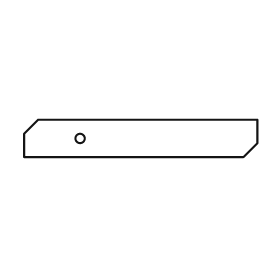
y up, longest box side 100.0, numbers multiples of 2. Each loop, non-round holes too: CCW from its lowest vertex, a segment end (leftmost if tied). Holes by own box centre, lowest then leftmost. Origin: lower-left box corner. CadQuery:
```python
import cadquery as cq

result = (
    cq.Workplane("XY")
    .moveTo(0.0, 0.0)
    .lineTo(94.0, 0.0)
    .lineTo(100.0, 6.0)
    .lineTo(100.0, 16.0)
    .lineTo(6.0, 16.0)
    .lineTo(0.0, 10.0)
    .close()
    .moveTo(24.0, 8.0)
    .circle(2.0)
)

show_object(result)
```